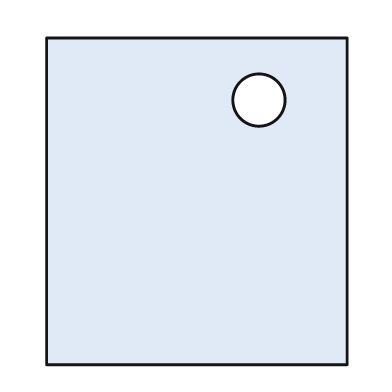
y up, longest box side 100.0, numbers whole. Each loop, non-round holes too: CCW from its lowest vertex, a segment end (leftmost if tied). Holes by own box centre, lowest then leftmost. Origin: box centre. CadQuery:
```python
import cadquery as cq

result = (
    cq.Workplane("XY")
    .moveTo(-46.0, -50.0)
    .lineTo(46.0, -50.0)
    .lineTo(46.0, 50.0)
    .lineTo(-46.0, 50.0)
    .close()
    .moveTo(19.0, 31.0)
    .circle(8.0)
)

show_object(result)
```